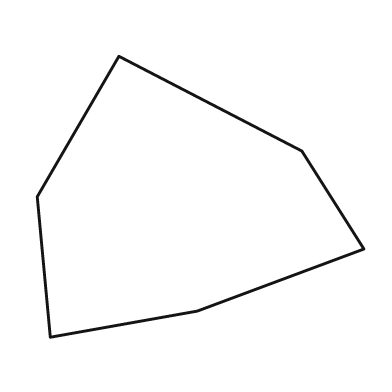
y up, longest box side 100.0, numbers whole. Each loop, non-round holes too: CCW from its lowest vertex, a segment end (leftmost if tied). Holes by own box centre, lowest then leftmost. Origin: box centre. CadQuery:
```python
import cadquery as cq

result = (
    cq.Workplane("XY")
    .moveTo(-46.0, -43.0)
    .lineTo(-1.0, -35.0)
    .lineTo(50.0, -16.0)
    .lineTo(31.0, 14.0)
    .lineTo(-25.0, 43.0)
    .lineTo(-50.0, 0.0)
    .close()
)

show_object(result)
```